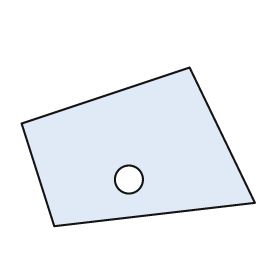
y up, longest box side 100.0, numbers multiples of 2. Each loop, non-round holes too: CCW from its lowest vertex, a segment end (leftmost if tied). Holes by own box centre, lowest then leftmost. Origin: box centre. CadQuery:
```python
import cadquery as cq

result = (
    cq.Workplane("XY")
    .moveTo(-36.0, -34.0)
    .lineTo(50.0, -24.0)
    .lineTo(22.0, 34.0)
    .lineTo(-50.0, 10.0)
    .close()
    .moveTo(-4.0, -14.0)
    .circle(6.0)
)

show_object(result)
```